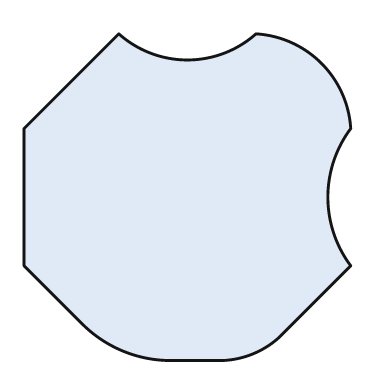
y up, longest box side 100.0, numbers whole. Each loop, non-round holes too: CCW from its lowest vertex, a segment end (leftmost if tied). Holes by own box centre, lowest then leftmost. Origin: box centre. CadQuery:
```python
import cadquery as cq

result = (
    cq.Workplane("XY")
    .moveTo(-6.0, -50.0)
    .lineTo(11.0, -50.0)
    .threePointArc((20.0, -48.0), (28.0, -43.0))
    .lineTo(50.0, -21.0)
    .threePointArc((43.0, 0.0), (50.0, 21.0))
    .threePointArc((41.0, 41.0), (21.0, 50.0))
    .threePointArc((0.0, 42.0), (-21.0, 50.0))
    .lineTo(-50.0, 21.0)
    .lineTo(-50.0, -21.0)
    .lineTo(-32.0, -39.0)
    .threePointArc((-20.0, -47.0), (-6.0, -50.0))
    .close()
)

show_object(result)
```